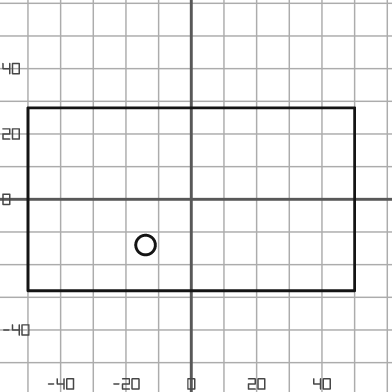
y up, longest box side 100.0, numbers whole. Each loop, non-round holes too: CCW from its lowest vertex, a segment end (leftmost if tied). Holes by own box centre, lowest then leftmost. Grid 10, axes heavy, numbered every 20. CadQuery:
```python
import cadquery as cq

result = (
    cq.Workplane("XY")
    .moveTo(-50.0, -28.0)
    .lineTo(50.0, -28.0)
    .lineTo(50.0, 28.0)
    .lineTo(-50.0, 28.0)
    .close()
    .moveTo(-14.0, -14.0)
    .circle(3.0)
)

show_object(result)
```